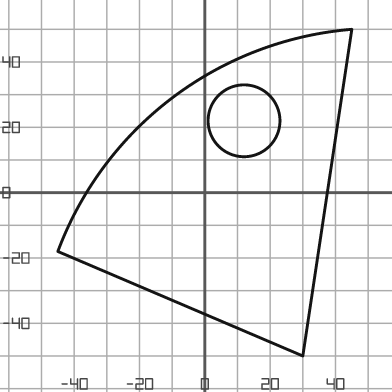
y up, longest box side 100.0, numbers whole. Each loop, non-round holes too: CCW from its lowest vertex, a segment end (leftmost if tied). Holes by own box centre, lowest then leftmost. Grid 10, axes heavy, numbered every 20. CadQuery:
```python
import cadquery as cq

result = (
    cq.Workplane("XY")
    .moveTo(30.0, -50.0)
    .lineTo(45.0, 50.0)
    .threePointArc((-10.0, 29.0), (-45.0, -18.0))
    .close()
    .moveTo(12.0, 22.0)
    .circle(11.0)
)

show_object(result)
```